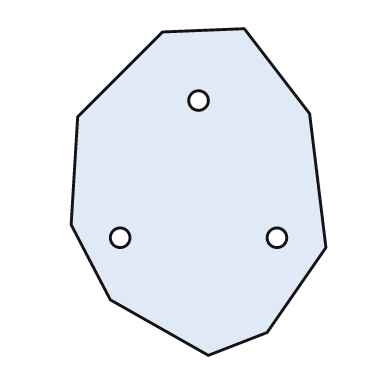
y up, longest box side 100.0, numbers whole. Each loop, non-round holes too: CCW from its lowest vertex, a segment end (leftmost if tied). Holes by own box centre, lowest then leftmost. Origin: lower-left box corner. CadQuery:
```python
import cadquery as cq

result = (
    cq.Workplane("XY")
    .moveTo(42.0, 0.0)
    .lineTo(60.0, 7.0)
    .lineTo(78.0, 33.0)
    .lineTo(73.0, 74.0)
    .lineTo(53.0, 100.0)
    .lineTo(28.0, 99.0)
    .lineTo(2.0, 73.0)
    .lineTo(0.0, 40.0)
    .lineTo(12.0, 17.0)
    .close()
    .moveTo(15.0, 36.0)
    .circle(3.0)
    .moveTo(63.0, 36.0)
    .circle(3.0)
    .moveTo(39.0, 78.0)
    .circle(3.0)
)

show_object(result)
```